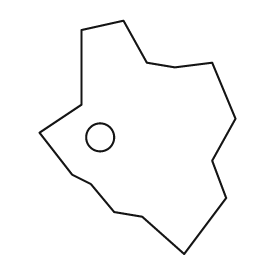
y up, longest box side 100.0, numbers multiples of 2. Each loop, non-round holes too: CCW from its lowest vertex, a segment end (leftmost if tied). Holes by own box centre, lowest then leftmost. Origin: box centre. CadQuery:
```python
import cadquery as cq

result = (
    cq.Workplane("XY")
    .moveTo(20.0, -50.0)
    .lineTo(38.0, -26.0)
    .lineTo(32.0, -10.0)
    .lineTo(42.0, 8.0)
    .lineTo(32.0, 32.0)
    .lineTo(16.0, 30.0)
    .lineTo(4.0, 32.0)
    .lineTo(-6.0, 50.0)
    .lineTo(-24.0, 46.0)
    .lineTo(-24.0, 14.0)
    .lineTo(-42.0, 2.0)
    .lineTo(-28.0, -16.0)
    .lineTo(-20.0, -20.0)
    .lineTo(-10.0, -32.0)
    .lineTo(2.0, -34.0)
    .close()
    .moveTo(-16.0, 0.0)
    .circle(6.0)
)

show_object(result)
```